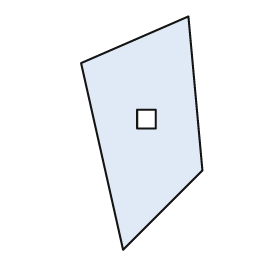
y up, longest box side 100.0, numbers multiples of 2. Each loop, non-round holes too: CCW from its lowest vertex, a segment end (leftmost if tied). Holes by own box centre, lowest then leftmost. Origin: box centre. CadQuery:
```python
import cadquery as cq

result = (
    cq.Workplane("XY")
    .moveTo(-8.0, -50.0)
    .lineTo(26.0, -16.0)
    .lineTo(20.0, 50.0)
    .lineTo(-26.0, 30.0)
    .close()
    .moveTo(-2.0, 2.0)
    .lineTo(6.0, 2.0)
    .lineTo(6.0, 10.0)
    .lineTo(-2.0, 10.0)
    .close()
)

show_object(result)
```